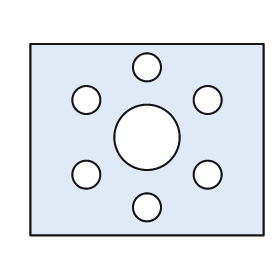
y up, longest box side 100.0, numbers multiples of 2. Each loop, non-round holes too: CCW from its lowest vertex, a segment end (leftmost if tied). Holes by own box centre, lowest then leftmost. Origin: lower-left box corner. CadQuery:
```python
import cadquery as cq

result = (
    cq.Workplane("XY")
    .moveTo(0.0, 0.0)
    .lineTo(100.0, 0.0)
    .lineTo(100.0, 82.0)
    .lineTo(0.0, 82.0)
    .close()
    .moveTo(50.0, 12.0)
    .circle(6.0)
    .moveTo(24.0, 26.0)
    .circle(6.0)
    .moveTo(76.0, 26.0)
    .circle(6.0)
    .moveTo(50.0, 42.0)
    .circle(14.0)
    .moveTo(24.0, 58.0)
    .circle(6.0)
    .moveTo(76.0, 58.0)
    .circle(6.0)
    .moveTo(50.0, 72.0)
    .circle(6.0)
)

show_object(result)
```